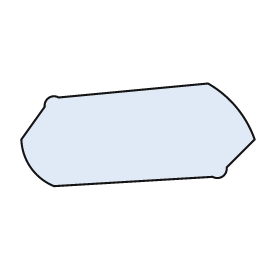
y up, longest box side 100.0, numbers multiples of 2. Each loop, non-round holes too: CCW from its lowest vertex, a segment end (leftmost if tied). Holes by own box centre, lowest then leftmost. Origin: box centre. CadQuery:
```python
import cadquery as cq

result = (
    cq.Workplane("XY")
    .moveTo(-36.0, -22.0)
    .lineTo(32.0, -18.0)
    .threePointArc((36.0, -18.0), (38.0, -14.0))
    .lineTo(50.0, -2.0)
    .threePointArc((42.0, 12.0), (30.0, 22.0))
    .lineTo(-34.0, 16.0)
    .threePointArc((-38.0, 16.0), (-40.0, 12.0))
    .lineTo(-50.0, -2.0)
    .threePointArc((-46.0, -14.0), (-36.0, -22.0))
    .close()
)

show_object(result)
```